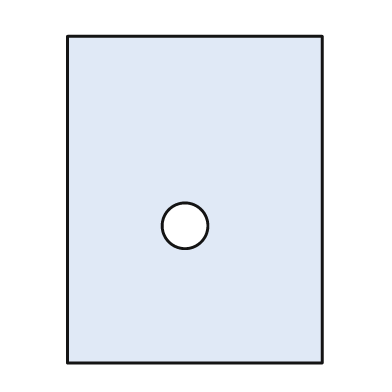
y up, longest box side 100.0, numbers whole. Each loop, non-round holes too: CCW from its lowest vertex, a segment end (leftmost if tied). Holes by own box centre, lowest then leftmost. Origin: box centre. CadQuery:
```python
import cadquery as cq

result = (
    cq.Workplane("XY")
    .moveTo(-39.0, -50.0)
    .lineTo(39.0, -50.0)
    .lineTo(39.0, 50.0)
    .lineTo(-39.0, 50.0)
    .close()
    .moveTo(-3.0, -8.0)
    .circle(7.0)
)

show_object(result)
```